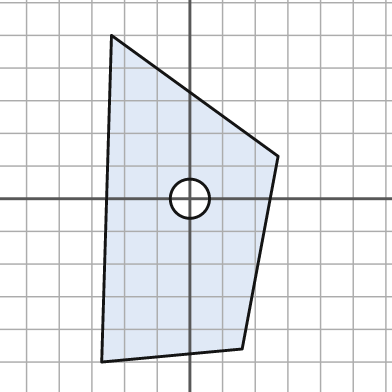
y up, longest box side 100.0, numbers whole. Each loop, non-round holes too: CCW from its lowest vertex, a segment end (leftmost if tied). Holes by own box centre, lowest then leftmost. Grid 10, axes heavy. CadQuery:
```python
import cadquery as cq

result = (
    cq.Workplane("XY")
    .moveTo(-27.0, -50.0)
    .lineTo(16.0, -46.0)
    .lineTo(27.0, 13.0)
    .lineTo(-24.0, 50.0)
    .close()
    .moveTo(0.0, 0.0)
    .circle(6.0)
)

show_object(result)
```